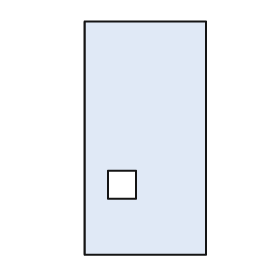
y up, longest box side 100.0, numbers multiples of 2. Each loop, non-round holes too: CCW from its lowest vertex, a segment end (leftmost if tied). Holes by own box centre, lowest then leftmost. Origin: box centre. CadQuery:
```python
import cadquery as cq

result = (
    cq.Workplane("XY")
    .moveTo(-26.0, -50.0)
    .lineTo(26.0, -50.0)
    .lineTo(26.0, 50.0)
    .lineTo(-26.0, 50.0)
    .close()
    .moveTo(-16.0, -26.0)
    .lineTo(-4.0, -26.0)
    .lineTo(-4.0, -14.0)
    .lineTo(-16.0, -14.0)
    .close()
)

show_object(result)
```